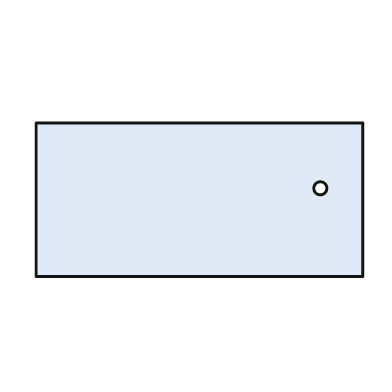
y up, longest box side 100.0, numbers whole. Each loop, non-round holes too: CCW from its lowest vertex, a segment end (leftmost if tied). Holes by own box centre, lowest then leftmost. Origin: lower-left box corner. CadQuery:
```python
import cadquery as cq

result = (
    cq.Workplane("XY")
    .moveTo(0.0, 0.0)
    .lineTo(100.0, 0.0)
    .lineTo(100.0, 47.0)
    .lineTo(0.0, 47.0)
    .close()
    .moveTo(87.0, 27.0)
    .circle(2.0)
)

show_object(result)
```